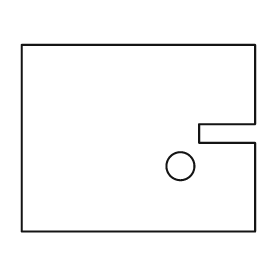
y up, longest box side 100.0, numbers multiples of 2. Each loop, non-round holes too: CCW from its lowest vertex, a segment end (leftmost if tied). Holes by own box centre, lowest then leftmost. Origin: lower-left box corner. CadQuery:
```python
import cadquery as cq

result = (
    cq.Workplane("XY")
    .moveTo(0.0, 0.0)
    .lineTo(100.0, 0.0)
    .lineTo(100.0, 38.0)
    .lineTo(76.0, 38.0)
    .lineTo(76.0, 46.0)
    .lineTo(100.0, 46.0)
    .lineTo(100.0, 80.0)
    .lineTo(0.0, 80.0)
    .close()
    .moveTo(68.0, 28.0)
    .circle(6.0)
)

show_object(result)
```